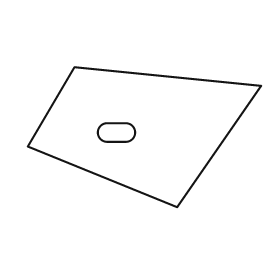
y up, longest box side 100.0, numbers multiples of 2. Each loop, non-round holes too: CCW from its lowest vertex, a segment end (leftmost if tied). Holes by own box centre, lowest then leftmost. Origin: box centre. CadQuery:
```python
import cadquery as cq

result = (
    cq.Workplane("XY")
    .moveTo(14.0, -30.0)
    .lineTo(50.0, 22.0)
    .lineTo(-30.0, 30.0)
    .lineTo(-50.0, -4.0)
    .close()
    .moveTo(-16.0, -2.0)
    .lineTo(-8.0, -2.0)
    .threePointArc((-4.0, 2.0), (-8.0, 6.0))
    .lineTo(-16.0, 6.0)
    .threePointArc((-20.0, 2.0), (-16.0, -2.0))
    .close()
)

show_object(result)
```